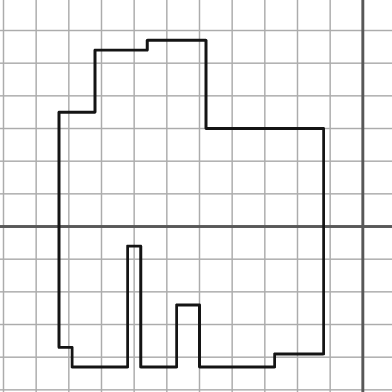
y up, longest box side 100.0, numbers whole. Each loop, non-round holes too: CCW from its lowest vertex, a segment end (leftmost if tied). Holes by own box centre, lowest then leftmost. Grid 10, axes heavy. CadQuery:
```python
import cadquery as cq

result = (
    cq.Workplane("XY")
    .moveTo(-89.0, -43.0)
    .lineTo(-72.0, -43.0)
    .lineTo(-72.0, -6.0)
    .lineTo(-68.0, -6.0)
    .lineTo(-68.0, -43.0)
    .lineTo(-57.0, -43.0)
    .lineTo(-57.0, -24.0)
    .lineTo(-50.0, -24.0)
    .lineTo(-50.0, -43.0)
    .lineTo(-27.0, -43.0)
    .lineTo(-27.0, -39.0)
    .lineTo(-12.0, -39.0)
    .lineTo(-12.0, 30.0)
    .lineTo(-48.0, 30.0)
    .lineTo(-48.0, 57.0)
    .lineTo(-66.0, 57.0)
    .lineTo(-66.0, 54.0)
    .lineTo(-82.0, 54.0)
    .lineTo(-82.0, 35.0)
    .lineTo(-93.0, 35.0)
    .lineTo(-93.0, -37.0)
    .lineTo(-89.0, -37.0)
    .close()
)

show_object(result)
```